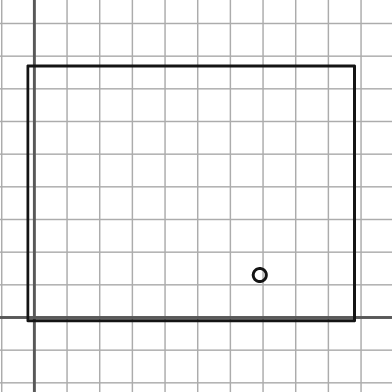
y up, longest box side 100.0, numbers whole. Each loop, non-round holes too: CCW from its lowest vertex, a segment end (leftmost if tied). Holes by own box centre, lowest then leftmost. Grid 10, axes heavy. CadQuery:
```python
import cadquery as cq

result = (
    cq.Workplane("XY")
    .moveTo(-2.0, -1.0)
    .lineTo(98.0, -1.0)
    .lineTo(98.0, 77.0)
    .lineTo(-2.0, 77.0)
    .close()
    .moveTo(69.0, 13.0)
    .circle(2.0)
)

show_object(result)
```